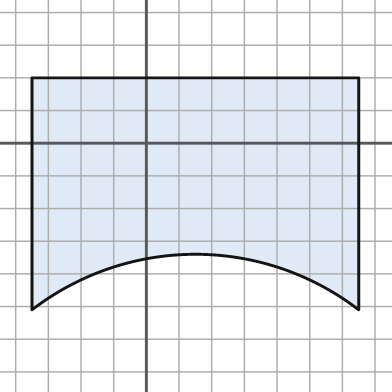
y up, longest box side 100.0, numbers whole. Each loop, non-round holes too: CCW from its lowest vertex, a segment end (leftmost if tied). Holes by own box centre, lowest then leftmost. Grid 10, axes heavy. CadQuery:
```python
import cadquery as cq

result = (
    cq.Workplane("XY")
    .moveTo(-35.0, -51.0)
    .threePointArc((15.0, -34.0), (65.0, -51.0))
    .lineTo(65.0, 20.0)
    .lineTo(-35.0, 20.0)
    .close()
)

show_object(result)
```